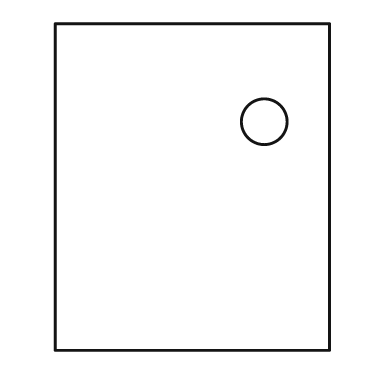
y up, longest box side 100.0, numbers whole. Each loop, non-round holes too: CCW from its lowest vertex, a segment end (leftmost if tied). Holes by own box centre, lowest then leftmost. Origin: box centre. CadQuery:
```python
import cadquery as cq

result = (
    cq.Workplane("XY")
    .moveTo(-42.0, -50.0)
    .lineTo(42.0, -50.0)
    .lineTo(42.0, 50.0)
    .lineTo(-42.0, 50.0)
    .close()
    .moveTo(22.0, 20.0)
    .circle(7.0)
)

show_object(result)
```